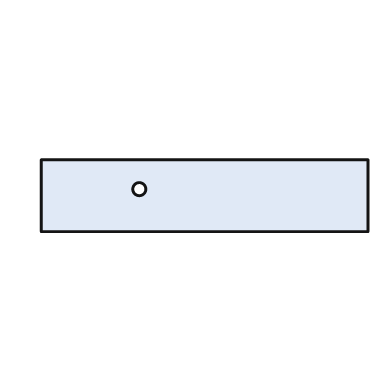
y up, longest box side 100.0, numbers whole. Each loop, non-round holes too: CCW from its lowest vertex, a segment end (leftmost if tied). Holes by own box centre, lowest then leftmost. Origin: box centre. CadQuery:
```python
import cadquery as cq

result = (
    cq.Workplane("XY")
    .moveTo(-50.0, -11.0)
    .lineTo(50.0, -11.0)
    .lineTo(50.0, 11.0)
    .lineTo(-50.0, 11.0)
    .close()
    .moveTo(-20.0, 2.0)
    .circle(2.0)
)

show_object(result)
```